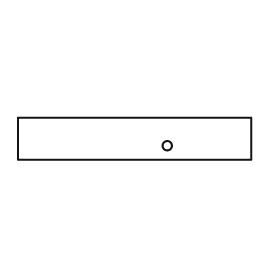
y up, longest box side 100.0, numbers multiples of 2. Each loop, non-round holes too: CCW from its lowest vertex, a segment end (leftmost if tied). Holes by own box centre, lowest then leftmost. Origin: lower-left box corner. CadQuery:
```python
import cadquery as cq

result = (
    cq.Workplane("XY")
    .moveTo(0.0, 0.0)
    .lineTo(100.0, 0.0)
    .lineTo(100.0, 18.0)
    .lineTo(0.0, 18.0)
    .close()
    .moveTo(64.0, 6.0)
    .circle(2.0)
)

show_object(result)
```